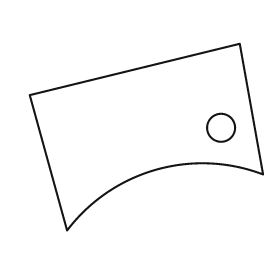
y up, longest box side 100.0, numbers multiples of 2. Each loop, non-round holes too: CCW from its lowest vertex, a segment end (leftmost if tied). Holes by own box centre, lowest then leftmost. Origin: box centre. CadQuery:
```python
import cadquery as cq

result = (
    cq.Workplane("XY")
    .moveTo(-34.0, -40.0)
    .threePointArc((4.0, -14.0), (50.0, -16.0))
    .lineTo(40.0, 40.0)
    .lineTo(-50.0, 18.0)
    .close()
    .moveTo(32.0, 4.0)
    .circle(6.0)
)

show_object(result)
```